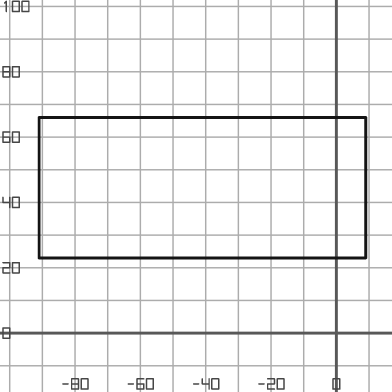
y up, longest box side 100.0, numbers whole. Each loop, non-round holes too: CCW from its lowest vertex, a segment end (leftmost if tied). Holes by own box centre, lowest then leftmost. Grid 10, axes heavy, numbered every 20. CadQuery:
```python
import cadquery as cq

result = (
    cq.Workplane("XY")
    .moveTo(-91.0, 23.0)
    .lineTo(9.0, 23.0)
    .lineTo(9.0, 66.0)
    .lineTo(-91.0, 66.0)
    .close()
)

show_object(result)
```